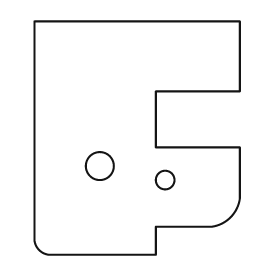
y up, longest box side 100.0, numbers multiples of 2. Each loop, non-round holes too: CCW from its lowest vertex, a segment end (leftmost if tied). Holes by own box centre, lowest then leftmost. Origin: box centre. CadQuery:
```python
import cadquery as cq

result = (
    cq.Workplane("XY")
    .moveTo(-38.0, -50.0)
    .lineTo(8.0, -50.0)
    .lineTo(8.0, -38.0)
    .lineTo(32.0, -38.0)
    .threePointArc((40.0, -34.0), (44.0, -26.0))
    .lineTo(44.0, -4.0)
    .lineTo(8.0, -4.0)
    .lineTo(8.0, 20.0)
    .lineTo(44.0, 20.0)
    .lineTo(44.0, 50.0)
    .lineTo(-44.0, 50.0)
    .lineTo(-44.0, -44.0)
    .threePointArc((-42.0, -48.0), (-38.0, -50.0))
    .close()
    .moveTo(12.0, -18.0)
    .circle(4.0)
    .moveTo(-16.0, -12.0)
    .circle(6.0)
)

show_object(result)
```